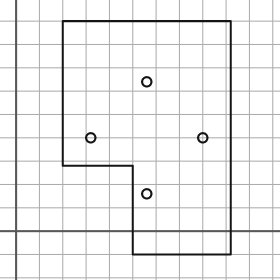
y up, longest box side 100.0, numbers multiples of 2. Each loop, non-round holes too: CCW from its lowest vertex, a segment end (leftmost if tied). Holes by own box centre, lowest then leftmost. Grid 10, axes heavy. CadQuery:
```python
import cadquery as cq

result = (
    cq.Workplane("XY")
    .moveTo(50.0, -10.0)
    .lineTo(92.0, -10.0)
    .lineTo(92.0, 90.0)
    .lineTo(20.0, 90.0)
    .lineTo(20.0, 28.0)
    .lineTo(50.0, 28.0)
    .close()
    .moveTo(56.0, 16.0)
    .circle(2.0)
    .moveTo(32.0, 40.0)
    .circle(2.0)
    .moveTo(80.0, 40.0)
    .circle(2.0)
    .moveTo(56.0, 64.0)
    .circle(2.0)
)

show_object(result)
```